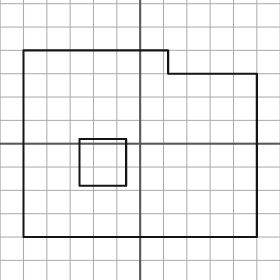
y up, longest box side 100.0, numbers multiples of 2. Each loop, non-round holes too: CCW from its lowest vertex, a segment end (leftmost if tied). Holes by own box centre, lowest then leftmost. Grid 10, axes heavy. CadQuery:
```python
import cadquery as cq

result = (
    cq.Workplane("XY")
    .moveTo(-50.0, -40.0)
    .lineTo(50.0, -40.0)
    .lineTo(50.0, 30.0)
    .lineTo(12.0, 30.0)
    .lineTo(12.0, 40.0)
    .lineTo(-50.0, 40.0)
    .close()
    .moveTo(-26.0, -18.0)
    .lineTo(-6.0, -18.0)
    .lineTo(-6.0, 2.0)
    .lineTo(-26.0, 2.0)
    .close()
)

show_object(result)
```